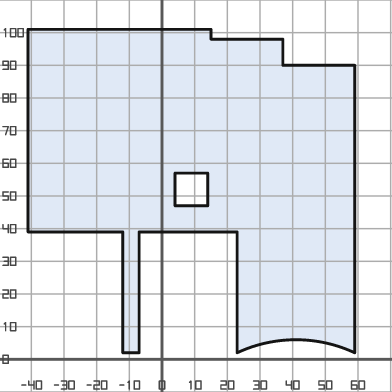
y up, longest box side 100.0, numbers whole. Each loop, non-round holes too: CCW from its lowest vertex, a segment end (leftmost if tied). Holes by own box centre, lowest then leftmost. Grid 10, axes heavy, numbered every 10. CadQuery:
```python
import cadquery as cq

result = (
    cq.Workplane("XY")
    .moveTo(-12.0, 2.0)
    .lineTo(-7.0, 2.0)
    .lineTo(-7.0, 39.0)
    .lineTo(23.0, 39.0)
    .lineTo(23.0, 2.0)
    .threePointArc((41.0, 6.0), (59.0, 2.0))
    .lineTo(59.0, 90.0)
    .lineTo(37.0, 90.0)
    .lineTo(37.0, 98.0)
    .lineTo(15.0, 98.0)
    .lineTo(15.0, 101.0)
    .lineTo(-41.0, 101.0)
    .lineTo(-41.0, 39.0)
    .lineTo(-12.0, 39.0)
    .close()
    .moveTo(4.0, 47.0)
    .lineTo(14.0, 47.0)
    .lineTo(14.0, 57.0)
    .lineTo(4.0, 57.0)
    .close()
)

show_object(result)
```